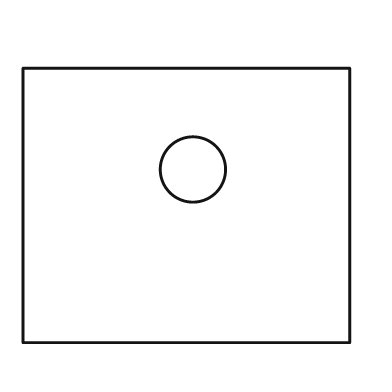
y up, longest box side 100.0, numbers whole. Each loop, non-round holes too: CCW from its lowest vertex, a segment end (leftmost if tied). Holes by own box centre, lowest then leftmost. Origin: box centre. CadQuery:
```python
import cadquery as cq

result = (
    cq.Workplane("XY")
    .moveTo(-50.0, -42.0)
    .lineTo(50.0, -42.0)
    .lineTo(50.0, 42.0)
    .lineTo(-50.0, 42.0)
    .close()
    .moveTo(2.0, 11.0)
    .circle(10.0)
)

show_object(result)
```